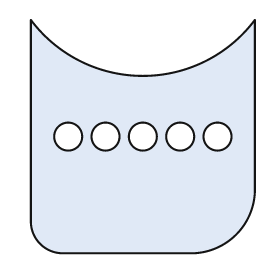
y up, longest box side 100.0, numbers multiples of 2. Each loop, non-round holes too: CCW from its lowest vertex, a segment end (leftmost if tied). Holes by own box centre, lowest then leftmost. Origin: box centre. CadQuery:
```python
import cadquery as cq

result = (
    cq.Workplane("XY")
    .moveTo(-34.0, -50.0)
    .lineTo(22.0, -50.0)
    .threePointArc((40.0, -42.0), (48.0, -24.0))
    .lineTo(48.0, 50.0)
    .threePointArc((0.0, 26.0), (-48.0, 50.0))
    .lineTo(-48.0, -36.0)
    .threePointArc((-44.0, -46.0), (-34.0, -50.0))
    .close()
    .moveTo(-32.0, 0.0)
    .circle(6.0)
    .moveTo(-16.0, 0.0)
    .circle(6.0)
    .moveTo(0.0, 0.0)
    .circle(6.0)
    .moveTo(16.0, 0.0)
    .circle(6.0)
    .moveTo(32.0, 0.0)
    .circle(6.0)
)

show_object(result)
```